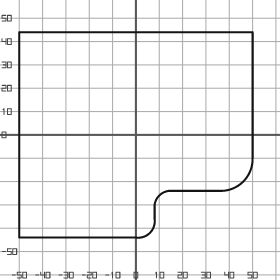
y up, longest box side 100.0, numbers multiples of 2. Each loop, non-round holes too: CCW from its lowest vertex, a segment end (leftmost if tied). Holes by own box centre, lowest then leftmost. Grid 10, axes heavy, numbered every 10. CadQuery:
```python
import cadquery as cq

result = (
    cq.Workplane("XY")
    .moveTo(-50.0, -44.0)
    .lineTo(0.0, -44.0)
    .threePointArc((6.0, -42.0), (8.0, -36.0))
    .lineTo(8.0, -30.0)
    .threePointArc((10.0, -26.0), (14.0, -24.0))
    .lineTo(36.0, -24.0)
    .threePointArc((46.0, -20.0), (50.0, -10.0))
    .lineTo(50.0, 44.0)
    .lineTo(-50.0, 44.0)
    .close()
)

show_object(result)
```